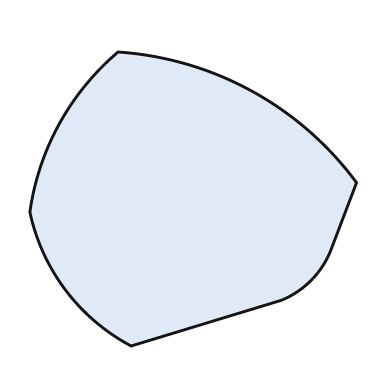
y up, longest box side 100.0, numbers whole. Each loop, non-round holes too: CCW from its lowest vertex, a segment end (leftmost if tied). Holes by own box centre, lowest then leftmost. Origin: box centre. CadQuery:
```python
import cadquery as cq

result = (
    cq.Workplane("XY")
    .moveTo(-19.0, -45.0)
    .lineTo(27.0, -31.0)
    .threePointArc((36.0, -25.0), (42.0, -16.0))
    .lineTo(50.0, 5.0)
    .threePointArc((18.0, 33.0), (-23.0, 45.0))
    .threePointArc((-41.0, 23.0), (-50.0, -4.0))
    .threePointArc((-39.0, -28.0), (-19.0, -45.0))
    .close()
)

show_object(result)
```